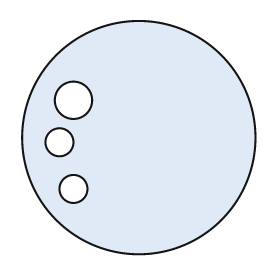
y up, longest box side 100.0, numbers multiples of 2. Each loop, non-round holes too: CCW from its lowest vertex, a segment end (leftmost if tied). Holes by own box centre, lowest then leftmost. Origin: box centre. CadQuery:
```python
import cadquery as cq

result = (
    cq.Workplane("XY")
    .moveTo(0.0, 0.0)
    .circle(50.0)
    .moveTo(-28.0, -22.0)
    .circle(6.0)
    .moveTo(-34.0, -2.0)
    .circle(6.0)
    .moveTo(-28.0, 16.0)
    .circle(8.0)
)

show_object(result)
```